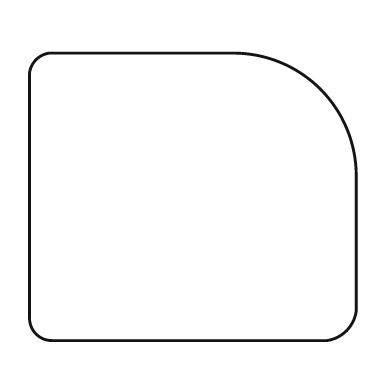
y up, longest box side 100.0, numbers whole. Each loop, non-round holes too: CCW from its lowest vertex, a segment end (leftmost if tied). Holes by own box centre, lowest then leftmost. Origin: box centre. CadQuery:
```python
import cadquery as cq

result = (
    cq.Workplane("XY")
    .moveTo(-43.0, -44.0)
    .lineTo(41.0, -44.0)
    .threePointArc((47.0, -41.0), (50.0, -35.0))
    .lineTo(50.0, 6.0)
    .threePointArc((39.0, 33.0), (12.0, 44.0))
    .lineTo(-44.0, 44.0)
    .threePointArc((-48.0, 42.0), (-50.0, 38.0))
    .lineTo(-50.0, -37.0)
    .threePointArc((-48.0, -42.0), (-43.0, -44.0))
    .close()
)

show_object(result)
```